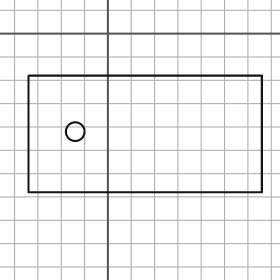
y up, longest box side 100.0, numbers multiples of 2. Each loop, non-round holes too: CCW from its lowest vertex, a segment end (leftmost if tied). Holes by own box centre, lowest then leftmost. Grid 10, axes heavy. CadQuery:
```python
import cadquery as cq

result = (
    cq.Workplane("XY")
    .moveTo(-34.0, -68.0)
    .lineTo(66.0, -68.0)
    .lineTo(66.0, -18.0)
    .lineTo(-34.0, -18.0)
    .close()
    .moveTo(-14.0, -42.0)
    .circle(4.0)
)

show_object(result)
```